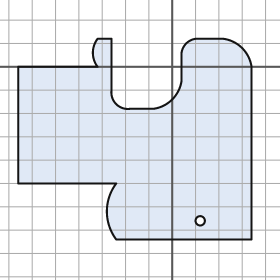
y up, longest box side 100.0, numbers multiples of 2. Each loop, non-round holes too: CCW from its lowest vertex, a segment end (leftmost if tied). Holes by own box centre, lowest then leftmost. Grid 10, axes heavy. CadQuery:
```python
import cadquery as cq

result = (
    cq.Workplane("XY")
    .moveTo(-24.0, -74.0)
    .lineTo(34.0, -74.0)
    .lineTo(34.0, 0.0)
    .threePointArc((30.0, 8.0), (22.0, 12.0))
    .lineTo(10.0, 12.0)
    .threePointArc((6.0, 10.0), (4.0, 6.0))
    .lineTo(4.0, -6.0)
    .threePointArc((0.0, -14.0), (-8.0, -18.0))
    .lineTo(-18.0, -18.0)
    .threePointArc((-24.0, -16.0), (-26.0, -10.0))
    .lineTo(-26.0, 12.0)
    .lineTo(-32.0, 12.0)
    .threePointArc((-34.0, 6.0), (-32.0, 0.0))
    .lineTo(-66.0, 0.0)
    .lineTo(-66.0, -50.0)
    .lineTo(-24.0, -50.0)
    .threePointArc((-28.0, -62.0), (-24.0, -74.0))
    .close()
    .moveTo(12.0, -66.0)
    .circle(2.0)
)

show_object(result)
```